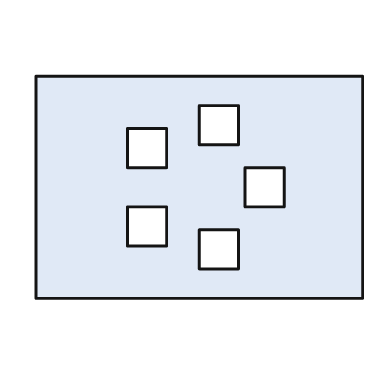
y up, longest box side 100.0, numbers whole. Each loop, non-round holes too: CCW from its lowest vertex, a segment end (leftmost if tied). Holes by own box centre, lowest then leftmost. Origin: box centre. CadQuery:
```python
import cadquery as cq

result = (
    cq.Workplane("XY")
    .moveTo(-50.0, -34.0)
    .lineTo(50.0, -34.0)
    .lineTo(50.0, 34.0)
    .lineTo(-50.0, 34.0)
    .close()
    .moveTo(0.0, -25.0)
    .lineTo(12.0, -25.0)
    .lineTo(12.0, -13.0)
    .lineTo(0.0, -13.0)
    .close()
    .moveTo(-22.0, -18.0)
    .lineTo(-10.0, -18.0)
    .lineTo(-10.0, -6.0)
    .lineTo(-22.0, -6.0)
    .close()
    .moveTo(14.0, -6.0)
    .lineTo(26.0, -6.0)
    .lineTo(26.0, 6.0)
    .lineTo(14.0, 6.0)
    .close()
    .moveTo(-22.0, 6.0)
    .lineTo(-10.0, 6.0)
    .lineTo(-10.0, 18.0)
    .lineTo(-22.0, 18.0)
    .close()
    .moveTo(0.0, 13.0)
    .lineTo(12.0, 13.0)
    .lineTo(12.0, 25.0)
    .lineTo(0.0, 25.0)
    .close()
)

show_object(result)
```